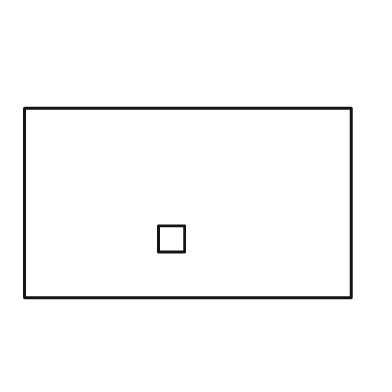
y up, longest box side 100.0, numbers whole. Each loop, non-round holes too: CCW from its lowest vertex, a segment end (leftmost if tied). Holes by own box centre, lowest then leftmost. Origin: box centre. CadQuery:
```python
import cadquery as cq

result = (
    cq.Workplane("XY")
    .moveTo(-50.0, -29.0)
    .lineTo(50.0, -29.0)
    .lineTo(50.0, 29.0)
    .lineTo(-50.0, 29.0)
    .close()
    .moveTo(-9.0, -15.0)
    .lineTo(-1.0, -15.0)
    .lineTo(-1.0, -7.0)
    .lineTo(-9.0, -7.0)
    .close()
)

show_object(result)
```